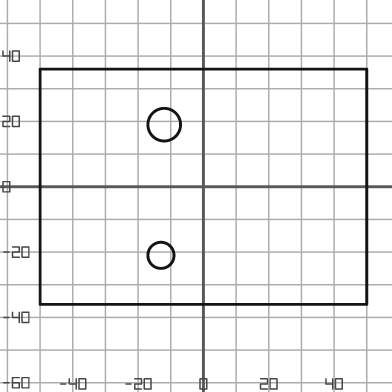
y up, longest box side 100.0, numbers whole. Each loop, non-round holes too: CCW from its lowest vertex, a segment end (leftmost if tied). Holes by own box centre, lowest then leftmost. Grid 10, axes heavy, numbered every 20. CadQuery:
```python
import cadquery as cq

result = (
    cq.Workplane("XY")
    .moveTo(-50.0, -36.0)
    .lineTo(50.0, -36.0)
    .lineTo(50.0, 36.0)
    .lineTo(-50.0, 36.0)
    .close()
    .moveTo(-13.0, -21.0)
    .circle(4.0)
    .moveTo(-12.0, 19.0)
    .circle(5.0)
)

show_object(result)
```